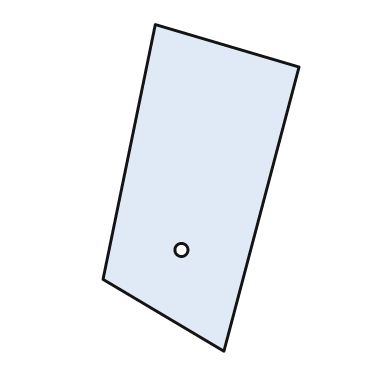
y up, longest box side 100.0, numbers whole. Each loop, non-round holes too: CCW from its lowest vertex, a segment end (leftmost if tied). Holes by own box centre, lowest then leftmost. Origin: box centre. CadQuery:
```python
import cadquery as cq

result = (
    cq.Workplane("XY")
    .moveTo(7.0, -50.0)
    .lineTo(30.0, 37.0)
    .lineTo(-14.0, 50.0)
    .lineTo(-30.0, -28.0)
    .close()
    .moveTo(-6.0, -19.0)
    .circle(2.0)
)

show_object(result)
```